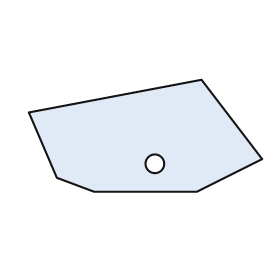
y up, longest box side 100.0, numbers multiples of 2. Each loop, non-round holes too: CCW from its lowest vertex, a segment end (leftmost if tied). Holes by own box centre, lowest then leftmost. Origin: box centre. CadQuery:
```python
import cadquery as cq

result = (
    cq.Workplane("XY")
    .moveTo(-22.0, -24.0)
    .lineTo(22.0, -24.0)
    .lineTo(50.0, -10.0)
    .lineTo(24.0, 24.0)
    .lineTo(-50.0, 10.0)
    .lineTo(-38.0, -18.0)
    .close()
    .moveTo(4.0, -12.0)
    .circle(4.0)
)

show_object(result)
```